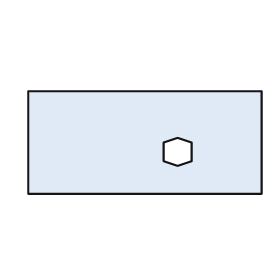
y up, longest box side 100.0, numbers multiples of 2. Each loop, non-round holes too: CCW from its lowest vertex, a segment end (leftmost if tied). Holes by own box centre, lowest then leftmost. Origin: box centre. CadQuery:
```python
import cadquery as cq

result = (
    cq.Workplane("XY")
    .moveTo(-50.0, -22.0)
    .lineTo(50.0, -22.0)
    .lineTo(50.0, 22.0)
    .lineTo(-50.0, 22.0)
    .close()
    .moveTo(14.0, -10.0)
    .lineTo(20.0, -8.0)
    .lineTo(20.0, 0.0)
    .lineTo(14.0, 2.0)
    .lineTo(8.0, 0.0)
    .lineTo(8.0, -8.0)
    .close()
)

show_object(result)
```